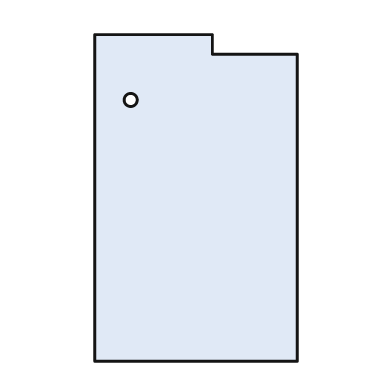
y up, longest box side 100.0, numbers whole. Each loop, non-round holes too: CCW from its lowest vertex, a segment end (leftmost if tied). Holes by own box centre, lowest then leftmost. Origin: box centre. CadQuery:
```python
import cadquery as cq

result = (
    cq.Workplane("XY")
    .moveTo(-31.0, -50.0)
    .lineTo(31.0, -50.0)
    .lineTo(31.0, 44.0)
    .lineTo(5.0, 44.0)
    .lineTo(5.0, 50.0)
    .lineTo(-31.0, 50.0)
    .close()
    .moveTo(-20.0, 30.0)
    .circle(2.0)
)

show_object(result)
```